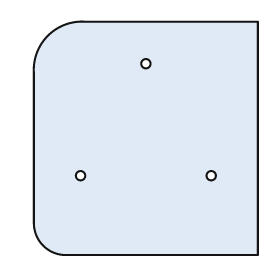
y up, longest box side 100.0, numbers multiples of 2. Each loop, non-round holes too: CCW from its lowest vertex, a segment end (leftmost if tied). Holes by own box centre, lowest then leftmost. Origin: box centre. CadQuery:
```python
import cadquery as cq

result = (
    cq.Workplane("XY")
    .moveTo(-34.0, -50.0)
    .lineTo(48.0, -50.0)
    .lineTo(48.0, 50.0)
    .lineTo(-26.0, 50.0)
    .threePointArc((-42.0, 44.0), (-48.0, 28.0))
    .lineTo(-48.0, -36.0)
    .threePointArc((-44.0, -46.0), (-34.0, -50.0))
    .close()
    .moveTo(-28.0, -16.0)
    .circle(2.0)
    .moveTo(28.0, -16.0)
    .circle(2.0)
    .moveTo(0.0, 32.0)
    .circle(2.0)
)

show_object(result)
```